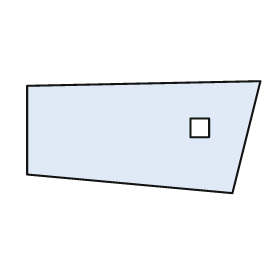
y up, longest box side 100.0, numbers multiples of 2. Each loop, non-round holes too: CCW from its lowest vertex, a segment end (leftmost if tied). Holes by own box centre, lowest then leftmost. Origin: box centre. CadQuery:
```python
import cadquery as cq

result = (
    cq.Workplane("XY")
    .moveTo(38.0, -24.0)
    .lineTo(50.0, 24.0)
    .lineTo(-50.0, 22.0)
    .lineTo(-50.0, -16.0)
    .close()
    .moveTo(20.0, 0.0)
    .lineTo(28.0, 0.0)
    .lineTo(28.0, 8.0)
    .lineTo(20.0, 8.0)
    .close()
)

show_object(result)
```